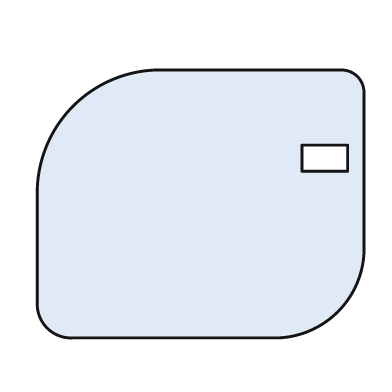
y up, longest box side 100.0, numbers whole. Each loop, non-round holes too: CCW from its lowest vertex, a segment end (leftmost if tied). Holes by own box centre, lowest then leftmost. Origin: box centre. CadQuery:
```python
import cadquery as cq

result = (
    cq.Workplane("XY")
    .moveTo(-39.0, -41.0)
    .lineTo(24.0, -41.0)
    .threePointArc((42.0, -33.0), (50.0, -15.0))
    .lineTo(50.0, 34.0)
    .threePointArc((48.0, 39.0), (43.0, 41.0))
    .lineTo(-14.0, 41.0)
    .threePointArc((-39.0, 30.0), (-50.0, 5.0))
    .lineTo(-50.0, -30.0)
    .threePointArc((-47.0, -38.0), (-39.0, -41.0))
    .close()
    .moveTo(31.0, 10.0)
    .lineTo(45.0, 10.0)
    .lineTo(45.0, 18.0)
    .lineTo(31.0, 18.0)
    .close()
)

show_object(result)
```